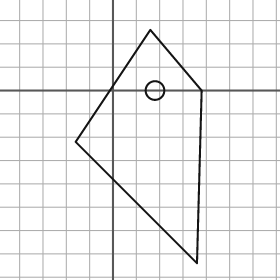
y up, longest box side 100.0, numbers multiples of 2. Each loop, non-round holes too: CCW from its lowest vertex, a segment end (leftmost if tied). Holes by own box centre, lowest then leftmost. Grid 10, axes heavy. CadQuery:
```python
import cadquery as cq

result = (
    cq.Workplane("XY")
    .moveTo(36.0, -74.0)
    .lineTo(38.0, 0.0)
    .lineTo(16.0, 26.0)
    .lineTo(-16.0, -22.0)
    .close()
    .moveTo(18.0, 0.0)
    .circle(4.0)
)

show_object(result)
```